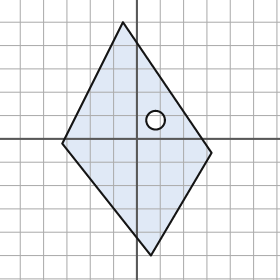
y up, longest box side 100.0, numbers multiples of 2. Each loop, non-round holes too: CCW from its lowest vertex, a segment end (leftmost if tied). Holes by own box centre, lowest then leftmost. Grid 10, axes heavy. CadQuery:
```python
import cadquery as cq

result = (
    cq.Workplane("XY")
    .moveTo(6.0, -50.0)
    .lineTo(32.0, -6.0)
    .lineTo(-6.0, 50.0)
    .lineTo(-32.0, -2.0)
    .close()
    .moveTo(8.0, 8.0)
    .circle(4.0)
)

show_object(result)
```